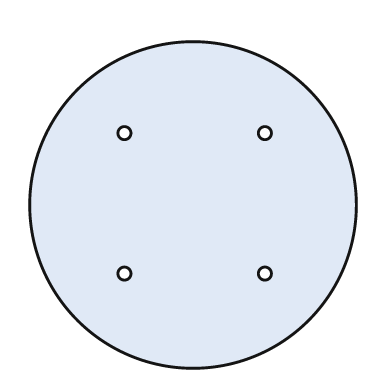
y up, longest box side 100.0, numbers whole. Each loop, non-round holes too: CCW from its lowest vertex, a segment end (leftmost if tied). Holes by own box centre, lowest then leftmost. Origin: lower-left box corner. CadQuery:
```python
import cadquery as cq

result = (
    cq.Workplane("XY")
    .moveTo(50.0, 50.0)
    .circle(50.0)
    .moveTo(29.0, 29.0)
    .circle(2.0)
    .moveTo(72.0, 29.0)
    .circle(2.0)
    .moveTo(29.0, 72.0)
    .circle(2.0)
    .moveTo(72.0, 72.0)
    .circle(2.0)
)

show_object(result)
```